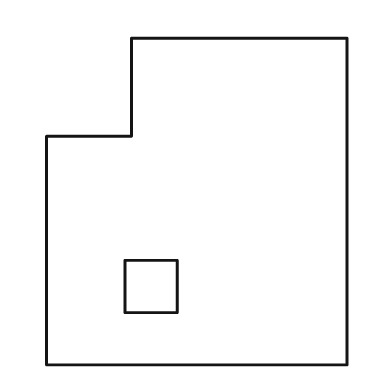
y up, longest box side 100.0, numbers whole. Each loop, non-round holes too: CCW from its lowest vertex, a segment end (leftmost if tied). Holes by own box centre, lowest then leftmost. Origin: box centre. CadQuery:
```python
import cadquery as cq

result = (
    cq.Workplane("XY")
    .moveTo(-46.0, -50.0)
    .lineTo(46.0, -50.0)
    .lineTo(46.0, 50.0)
    .lineTo(-20.0, 50.0)
    .lineTo(-20.0, 20.0)
    .lineTo(-46.0, 20.0)
    .close()
    .moveTo(-22.0, -34.0)
    .lineTo(-6.0, -34.0)
    .lineTo(-6.0, -18.0)
    .lineTo(-22.0, -18.0)
    .close()
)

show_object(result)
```